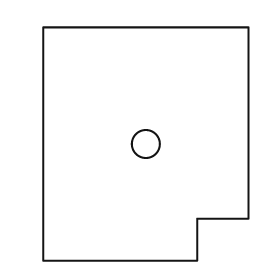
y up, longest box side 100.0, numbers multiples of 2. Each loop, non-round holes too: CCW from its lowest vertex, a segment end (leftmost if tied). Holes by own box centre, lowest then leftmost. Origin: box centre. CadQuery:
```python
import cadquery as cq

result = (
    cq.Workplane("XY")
    .moveTo(-44.0, -50.0)
    .lineTo(22.0, -50.0)
    .lineTo(22.0, -32.0)
    .lineTo(44.0, -32.0)
    .lineTo(44.0, 50.0)
    .lineTo(-44.0, 50.0)
    .close()
    .moveTo(0.0, 0.0)
    .circle(6.0)
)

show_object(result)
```